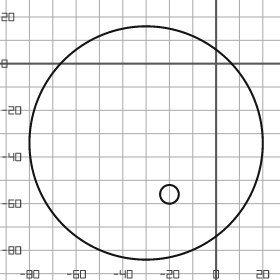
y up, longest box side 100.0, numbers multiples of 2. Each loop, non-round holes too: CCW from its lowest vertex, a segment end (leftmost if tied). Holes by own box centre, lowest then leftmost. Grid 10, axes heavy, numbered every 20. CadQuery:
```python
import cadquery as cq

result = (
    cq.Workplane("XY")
    .moveTo(-30.0, -34.0)
    .circle(50.0)
    .moveTo(-20.0, -56.0)
    .circle(4.0)
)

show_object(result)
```